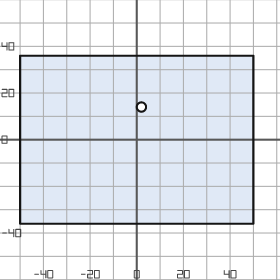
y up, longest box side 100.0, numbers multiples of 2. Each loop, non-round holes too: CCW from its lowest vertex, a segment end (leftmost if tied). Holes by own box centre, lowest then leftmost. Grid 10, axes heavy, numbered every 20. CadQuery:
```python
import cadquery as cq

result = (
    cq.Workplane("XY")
    .moveTo(-50.0, -36.0)
    .lineTo(50.0, -36.0)
    .lineTo(50.0, 36.0)
    .lineTo(-50.0, 36.0)
    .close()
    .moveTo(2.0, 14.0)
    .circle(2.0)
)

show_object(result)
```